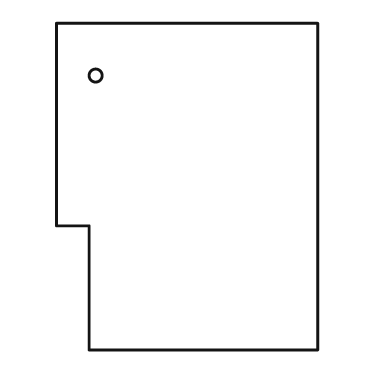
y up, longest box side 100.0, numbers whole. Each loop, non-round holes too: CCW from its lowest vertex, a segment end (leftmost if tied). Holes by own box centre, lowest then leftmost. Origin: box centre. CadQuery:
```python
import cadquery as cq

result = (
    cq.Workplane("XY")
    .moveTo(-30.0, -50.0)
    .lineTo(40.0, -50.0)
    .lineTo(40.0, 50.0)
    .lineTo(-40.0, 50.0)
    .lineTo(-40.0, -12.0)
    .lineTo(-30.0, -12.0)
    .close()
    .moveTo(-28.0, 34.0)
    .circle(2.0)
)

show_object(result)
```